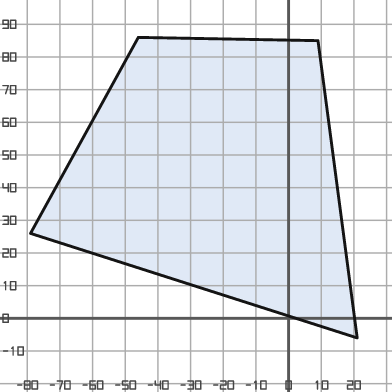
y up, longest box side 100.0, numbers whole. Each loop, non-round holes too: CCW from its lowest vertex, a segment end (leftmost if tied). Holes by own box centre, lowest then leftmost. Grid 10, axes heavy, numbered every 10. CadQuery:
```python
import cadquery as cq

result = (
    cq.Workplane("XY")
    .moveTo(21.0, -6.0)
    .lineTo(9.0, 85.0)
    .lineTo(-46.0, 86.0)
    .lineTo(-79.0, 26.0)
    .close()
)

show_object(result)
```